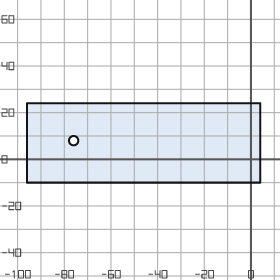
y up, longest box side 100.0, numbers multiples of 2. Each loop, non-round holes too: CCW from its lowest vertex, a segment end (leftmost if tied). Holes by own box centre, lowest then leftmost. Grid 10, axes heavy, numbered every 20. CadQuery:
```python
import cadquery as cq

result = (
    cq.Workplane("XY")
    .moveTo(-96.0, -10.0)
    .lineTo(4.0, -10.0)
    .lineTo(4.0, 24.0)
    .lineTo(-96.0, 24.0)
    .close()
    .moveTo(-76.0, 8.0)
    .circle(2.0)
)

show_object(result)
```